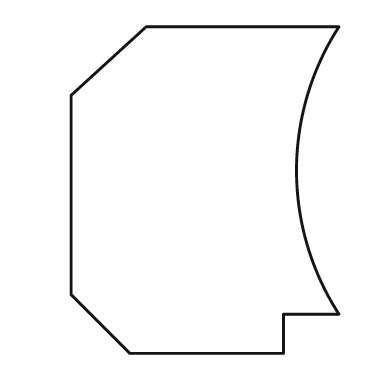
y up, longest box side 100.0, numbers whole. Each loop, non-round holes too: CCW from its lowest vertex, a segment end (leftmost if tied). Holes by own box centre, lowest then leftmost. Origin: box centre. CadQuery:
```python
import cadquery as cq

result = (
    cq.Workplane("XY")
    .moveTo(-23.0, -50.0)
    .lineTo(24.0, -50.0)
    .lineTo(24.0, -38.0)
    .lineTo(41.0, -38.0)
    .threePointArc((28.0, 6.0), (41.0, 50.0))
    .lineTo(-18.0, 50.0)
    .lineTo(-41.0, 29.0)
    .lineTo(-41.0, -32.0)
    .close()
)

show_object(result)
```